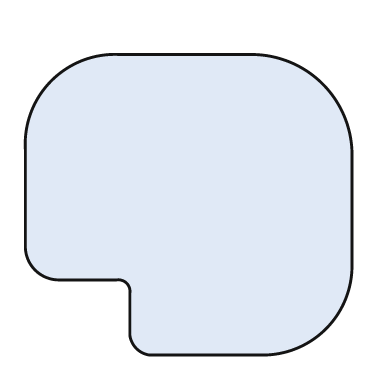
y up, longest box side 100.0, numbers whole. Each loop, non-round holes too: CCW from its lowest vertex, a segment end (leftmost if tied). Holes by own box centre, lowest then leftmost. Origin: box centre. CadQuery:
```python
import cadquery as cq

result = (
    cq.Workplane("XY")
    .moveTo(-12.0, -46.0)
    .lineTo(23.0, -46.0)
    .threePointArc((42.0, -38.0), (50.0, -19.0))
    .lineTo(50.0, 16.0)
    .threePointArc((41.0, 37.0), (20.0, 46.0))
    .lineTo(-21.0, 46.0)
    .threePointArc((-42.0, 38.0), (-50.0, 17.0))
    .lineTo(-50.0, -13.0)
    .threePointArc((-47.0, -20.0), (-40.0, -23.0))
    .lineTo(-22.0, -23.0)
    .threePointArc((-19.0, -24.0), (-18.0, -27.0))
    .lineTo(-18.0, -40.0)
    .threePointArc((-16.0, -44.0), (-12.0, -46.0))
    .close()
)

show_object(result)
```